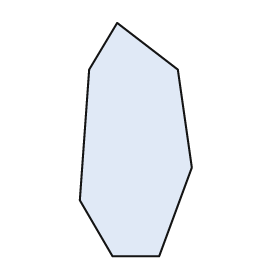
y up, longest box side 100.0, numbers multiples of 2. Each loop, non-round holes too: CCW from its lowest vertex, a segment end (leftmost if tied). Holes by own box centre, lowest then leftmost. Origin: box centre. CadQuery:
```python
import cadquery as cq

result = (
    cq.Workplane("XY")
    .moveTo(-10.0, -50.0)
    .lineTo(10.0, -50.0)
    .lineTo(24.0, -12.0)
    .lineTo(18.0, 30.0)
    .lineTo(-8.0, 50.0)
    .lineTo(-20.0, 30.0)
    .lineTo(-24.0, -26.0)
    .close()
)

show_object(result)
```